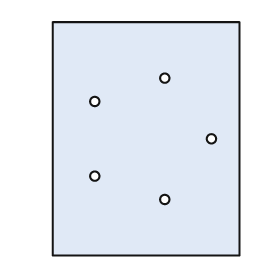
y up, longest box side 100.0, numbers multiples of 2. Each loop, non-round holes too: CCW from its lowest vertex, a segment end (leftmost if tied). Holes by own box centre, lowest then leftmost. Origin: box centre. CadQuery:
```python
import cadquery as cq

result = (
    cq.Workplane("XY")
    .moveTo(-40.0, -50.0)
    .lineTo(40.0, -50.0)
    .lineTo(40.0, 50.0)
    .lineTo(-40.0, 50.0)
    .close()
    .moveTo(8.0, -26.0)
    .circle(2.0)
    .moveTo(-22.0, -16.0)
    .circle(2.0)
    .moveTo(28.0, 0.0)
    .circle(2.0)
    .moveTo(-22.0, 16.0)
    .circle(2.0)
    .moveTo(8.0, 26.0)
    .circle(2.0)
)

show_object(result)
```